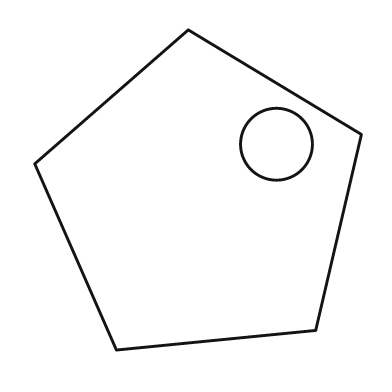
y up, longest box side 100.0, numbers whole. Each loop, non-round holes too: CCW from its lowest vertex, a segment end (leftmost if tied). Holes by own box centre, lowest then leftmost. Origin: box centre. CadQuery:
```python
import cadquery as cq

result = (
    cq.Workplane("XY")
    .moveTo(-25.0, -49.0)
    .lineTo(36.0, -43.0)
    .lineTo(50.0, 17.0)
    .lineTo(-3.0, 49.0)
    .lineTo(-50.0, 8.0)
    .close()
    .moveTo(24.0, 14.0)
    .circle(11.0)
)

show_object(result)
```